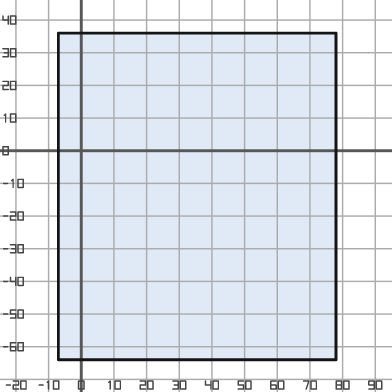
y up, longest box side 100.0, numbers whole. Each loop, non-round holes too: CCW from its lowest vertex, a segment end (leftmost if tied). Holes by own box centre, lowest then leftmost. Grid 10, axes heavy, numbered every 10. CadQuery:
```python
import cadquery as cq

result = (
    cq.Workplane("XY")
    .moveTo(-7.0, -64.0)
    .lineTo(78.0, -64.0)
    .lineTo(78.0, 36.0)
    .lineTo(-7.0, 36.0)
    .close()
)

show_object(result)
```